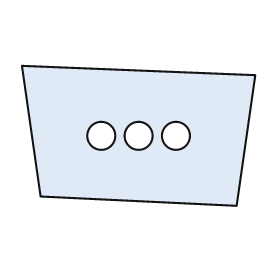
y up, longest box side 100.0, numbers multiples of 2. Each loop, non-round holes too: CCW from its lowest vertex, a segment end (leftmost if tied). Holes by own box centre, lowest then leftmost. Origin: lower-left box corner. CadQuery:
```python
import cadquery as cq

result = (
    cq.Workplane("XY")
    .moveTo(92.0, 0.0)
    .lineTo(100.0, 56.0)
    .lineTo(0.0, 60.0)
    .lineTo(8.0, 4.0)
    .close()
    .moveTo(34.0, 30.0)
    .circle(6.0)
    .moveTo(50.0, 30.0)
    .circle(6.0)
    .moveTo(66.0, 30.0)
    .circle(6.0)
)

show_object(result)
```